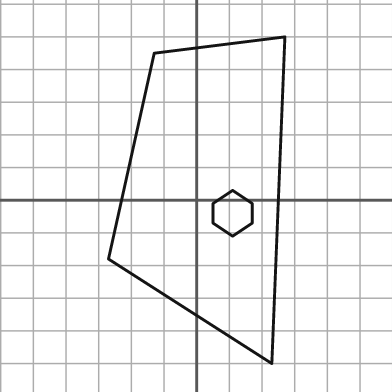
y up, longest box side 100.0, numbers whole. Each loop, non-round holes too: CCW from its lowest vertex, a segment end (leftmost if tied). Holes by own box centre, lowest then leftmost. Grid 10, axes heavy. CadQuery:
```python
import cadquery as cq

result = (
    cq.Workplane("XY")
    .moveTo(23.0, -50.0)
    .lineTo(27.0, 50.0)
    .lineTo(-13.0, 45.0)
    .lineTo(-27.0, -18.0)
    .close()
    .moveTo(11.0, -11.0)
    .lineTo(17.0, -7.0)
    .lineTo(17.0, -1.0)
    .lineTo(11.0, 3.0)
    .lineTo(5.0, -1.0)
    .lineTo(5.0, -7.0)
    .close()
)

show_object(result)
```